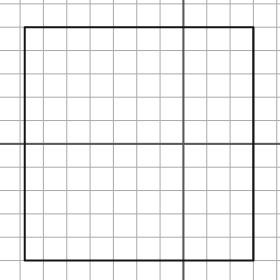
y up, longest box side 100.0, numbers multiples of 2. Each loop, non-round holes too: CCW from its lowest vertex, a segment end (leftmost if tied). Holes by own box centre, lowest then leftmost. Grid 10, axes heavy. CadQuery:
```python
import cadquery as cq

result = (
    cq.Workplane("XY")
    .moveTo(-68.0, -50.0)
    .lineTo(30.0, -50.0)
    .lineTo(30.0, 50.0)
    .lineTo(-68.0, 50.0)
    .close()
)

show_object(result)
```